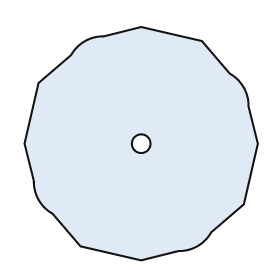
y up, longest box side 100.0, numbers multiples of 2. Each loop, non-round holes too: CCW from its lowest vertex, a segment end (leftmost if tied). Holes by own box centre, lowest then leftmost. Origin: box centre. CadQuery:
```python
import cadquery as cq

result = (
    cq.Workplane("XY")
    .moveTo(0.0, -50.0)
    .lineTo(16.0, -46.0)
    .threePointArc((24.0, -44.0), (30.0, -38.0))
    .lineTo(44.0, -26.0)
    .lineTo(50.0, 0.0)
    .lineTo(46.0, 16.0)
    .threePointArc((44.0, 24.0), (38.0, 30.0))
    .lineTo(26.0, 44.0)
    .lineTo(0.0, 50.0)
    .lineTo(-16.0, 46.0)
    .threePointArc((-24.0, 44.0), (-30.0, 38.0))
    .lineTo(-44.0, 26.0)
    .lineTo(-50.0, 0.0)
    .lineTo(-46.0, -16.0)
    .threePointArc((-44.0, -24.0), (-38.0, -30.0))
    .lineTo(-26.0, -44.0)
    .close()
    .moveTo(0.0, 0.0)
    .circle(4.0)
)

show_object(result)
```